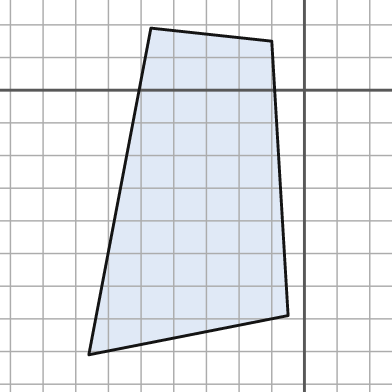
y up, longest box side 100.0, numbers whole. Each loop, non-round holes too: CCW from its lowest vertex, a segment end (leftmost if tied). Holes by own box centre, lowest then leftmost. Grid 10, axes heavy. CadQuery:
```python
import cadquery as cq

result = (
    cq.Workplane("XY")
    .moveTo(-66.0, -81.0)
    .lineTo(-5.0, -69.0)
    .lineTo(-10.0, 15.0)
    .lineTo(-47.0, 19.0)
    .close()
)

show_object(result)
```